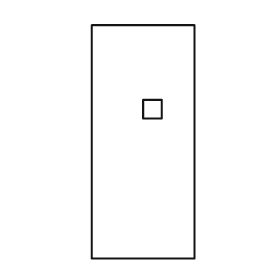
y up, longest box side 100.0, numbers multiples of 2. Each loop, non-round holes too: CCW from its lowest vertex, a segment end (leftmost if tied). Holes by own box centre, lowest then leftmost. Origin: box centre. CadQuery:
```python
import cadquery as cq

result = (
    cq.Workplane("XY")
    .moveTo(-22.0, -50.0)
    .lineTo(22.0, -50.0)
    .lineTo(22.0, 50.0)
    .lineTo(-22.0, 50.0)
    .close()
    .moveTo(0.0, 10.0)
    .lineTo(8.0, 10.0)
    .lineTo(8.0, 18.0)
    .lineTo(0.0, 18.0)
    .close()
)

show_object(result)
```